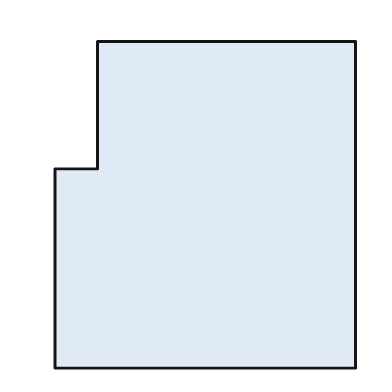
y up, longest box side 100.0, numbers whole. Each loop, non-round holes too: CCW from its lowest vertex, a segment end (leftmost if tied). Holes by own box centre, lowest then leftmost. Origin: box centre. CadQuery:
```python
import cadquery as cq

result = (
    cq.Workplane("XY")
    .moveTo(-46.0, -50.0)
    .lineTo(46.0, -50.0)
    .lineTo(46.0, 50.0)
    .lineTo(-33.0, 50.0)
    .lineTo(-33.0, 11.0)
    .lineTo(-46.0, 11.0)
    .close()
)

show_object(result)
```